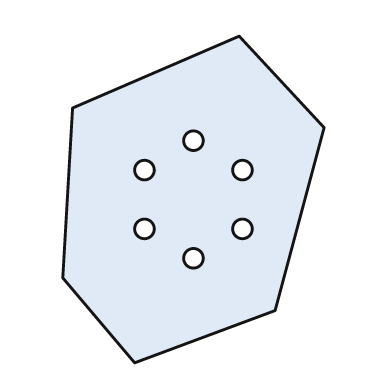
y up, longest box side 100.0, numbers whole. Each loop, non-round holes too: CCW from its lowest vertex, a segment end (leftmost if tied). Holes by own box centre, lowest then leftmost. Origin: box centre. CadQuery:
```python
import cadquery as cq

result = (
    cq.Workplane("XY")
    .moveTo(-18.0, -50.0)
    .lineTo(25.0, -34.0)
    .lineTo(40.0, 22.0)
    .lineTo(14.0, 50.0)
    .lineTo(-37.0, 28.0)
    .lineTo(-40.0, -24.0)
    .close()
    .moveTo(0.0, -18.0)
    .circle(3.0)
    .moveTo(-15.0, -9.0)
    .circle(3.0)
    .moveTo(15.0, -9.0)
    .circle(3.0)
    .moveTo(-15.0, 9.0)
    .circle(3.0)
    .moveTo(15.0, 9.0)
    .circle(3.0)
    .moveTo(0.0, 18.0)
    .circle(3.0)
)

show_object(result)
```